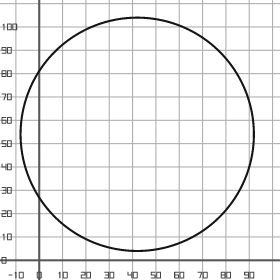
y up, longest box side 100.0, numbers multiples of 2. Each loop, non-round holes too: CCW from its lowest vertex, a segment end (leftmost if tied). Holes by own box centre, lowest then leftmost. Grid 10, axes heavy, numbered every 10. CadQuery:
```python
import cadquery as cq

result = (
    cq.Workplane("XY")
    .moveTo(42.0, 54.0)
    .circle(50.0)
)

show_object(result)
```